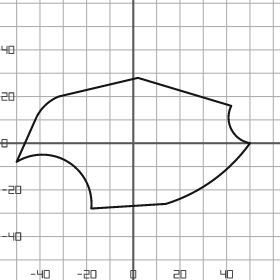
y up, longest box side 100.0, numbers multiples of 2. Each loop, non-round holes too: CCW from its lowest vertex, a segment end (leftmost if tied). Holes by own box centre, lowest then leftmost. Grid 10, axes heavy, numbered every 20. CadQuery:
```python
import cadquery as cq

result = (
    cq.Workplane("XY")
    .moveTo(-18.0, -28.0)
    .lineTo(14.0, -26.0)
    .threePointArc((34.0, -16.0), (50.0, 0.0))
    .threePointArc((42.0, 6.0), (42.0, 16.0))
    .lineTo(2.0, 28.0)
    .lineTo(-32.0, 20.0)
    .threePointArc((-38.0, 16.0), (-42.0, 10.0))
    .lineTo(-50.0, -8.0)
    .threePointArc((-28.0, -8.0), (-18.0, -28.0))
    .close()
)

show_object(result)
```